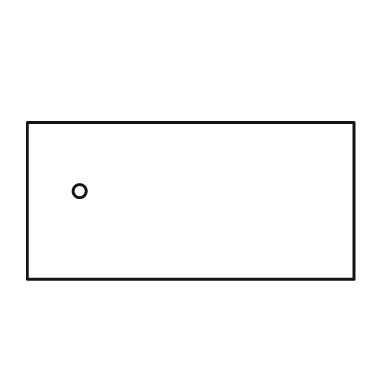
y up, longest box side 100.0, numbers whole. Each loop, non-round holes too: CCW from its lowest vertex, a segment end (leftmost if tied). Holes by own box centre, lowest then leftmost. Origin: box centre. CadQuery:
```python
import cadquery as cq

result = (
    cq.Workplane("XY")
    .moveTo(-50.0, -24.0)
    .lineTo(50.0, -24.0)
    .lineTo(50.0, 24.0)
    .lineTo(-50.0, 24.0)
    .close()
    .moveTo(-34.0, 3.0)
    .circle(2.0)
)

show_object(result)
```